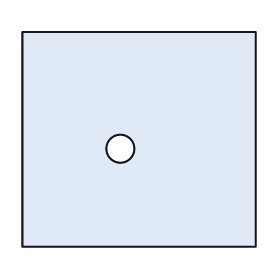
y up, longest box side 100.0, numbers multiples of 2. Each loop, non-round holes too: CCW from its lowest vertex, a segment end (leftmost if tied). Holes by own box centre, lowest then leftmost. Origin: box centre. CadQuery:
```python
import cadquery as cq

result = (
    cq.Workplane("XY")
    .moveTo(-50.0, -46.0)
    .lineTo(50.0, -46.0)
    .lineTo(50.0, 46.0)
    .lineTo(-50.0, 46.0)
    .close()
    .moveTo(-8.0, -4.0)
    .circle(6.0)
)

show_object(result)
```